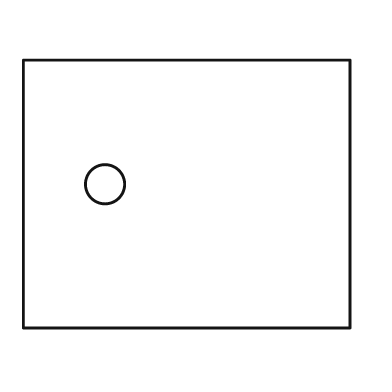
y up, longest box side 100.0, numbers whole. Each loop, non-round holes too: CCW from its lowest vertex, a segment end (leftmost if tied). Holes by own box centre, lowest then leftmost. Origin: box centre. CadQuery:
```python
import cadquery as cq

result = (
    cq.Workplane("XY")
    .moveTo(-50.0, -41.0)
    .lineTo(50.0, -41.0)
    .lineTo(50.0, 41.0)
    .lineTo(-50.0, 41.0)
    .close()
    .moveTo(-25.0, 3.0)
    .circle(6.0)
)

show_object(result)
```